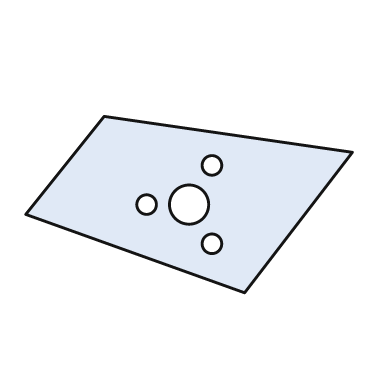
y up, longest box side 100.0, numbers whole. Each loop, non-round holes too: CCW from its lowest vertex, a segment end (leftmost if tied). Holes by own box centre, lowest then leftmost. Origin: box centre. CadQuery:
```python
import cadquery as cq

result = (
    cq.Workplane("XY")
    .moveTo(17.0, -27.0)
    .lineTo(50.0, 16.0)
    .lineTo(-26.0, 27.0)
    .lineTo(-50.0, -3.0)
    .close()
    .moveTo(7.0, -12.0)
    .circle(3.0)
    .moveTo(-13.0, 0.0)
    .circle(3.0)
    .moveTo(0.0, 0.0)
    .circle(6.0)
    .moveTo(7.0, 12.0)
    .circle(3.0)
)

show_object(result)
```